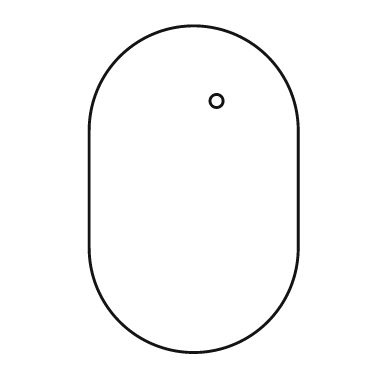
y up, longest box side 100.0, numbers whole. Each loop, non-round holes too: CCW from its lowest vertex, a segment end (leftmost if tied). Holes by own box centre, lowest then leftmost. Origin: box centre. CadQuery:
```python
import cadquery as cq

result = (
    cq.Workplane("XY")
    .moveTo(-32.0, -18.0)
    .threePointArc((0.0, -50.0), (32.0, -18.0))
    .lineTo(32.0, 18.0)
    .threePointArc((0.0, 50.0), (-32.0, 18.0))
    .close()
    .moveTo(7.0, 27.0)
    .circle(2.0)
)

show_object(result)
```